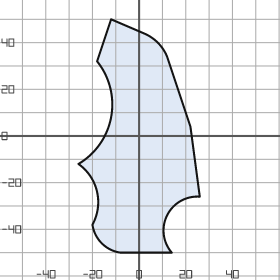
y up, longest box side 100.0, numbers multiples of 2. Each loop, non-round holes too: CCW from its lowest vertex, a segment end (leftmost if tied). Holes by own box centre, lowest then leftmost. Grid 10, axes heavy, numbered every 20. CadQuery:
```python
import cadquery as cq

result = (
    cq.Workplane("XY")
    .moveTo(-8.0, -50.0)
    .lineTo(14.0, -50.0)
    .threePointArc((12.0, -34.0), (26.0, -26.0))
    .lineTo(22.0, 4.0)
    .lineTo(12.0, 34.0)
    .threePointArc((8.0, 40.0), (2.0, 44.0))
    .lineTo(-12.0, 50.0)
    .lineTo(-18.0, 32.0)
    .threePointArc((-12.0, 8.0), (-26.0, -12.0))
    .threePointArc((-18.0, -24.0), (-20.0, -38.0))
    .threePointArc((-16.0, -46.0), (-8.0, -50.0))
    .close()
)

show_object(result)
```